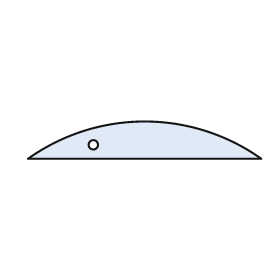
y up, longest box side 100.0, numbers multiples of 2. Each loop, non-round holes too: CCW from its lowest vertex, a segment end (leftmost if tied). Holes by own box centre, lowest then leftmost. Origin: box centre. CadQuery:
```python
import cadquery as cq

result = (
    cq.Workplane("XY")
    .moveTo(-50.0, -8.0)
    .lineTo(50.0, -8.0)
    .threePointArc((0.0, 8.0), (-50.0, -8.0))
    .close()
    .moveTo(-22.0, -2.0)
    .circle(2.0)
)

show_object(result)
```